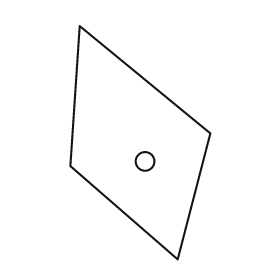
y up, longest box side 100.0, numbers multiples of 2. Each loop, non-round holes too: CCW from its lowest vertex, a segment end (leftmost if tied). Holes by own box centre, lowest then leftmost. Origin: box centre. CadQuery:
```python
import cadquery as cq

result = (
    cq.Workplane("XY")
    .moveTo(16.0, -50.0)
    .lineTo(30.0, 4.0)
    .lineTo(-26.0, 50.0)
    .lineTo(-30.0, -10.0)
    .close()
    .moveTo(2.0, -8.0)
    .circle(4.0)
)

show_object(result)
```